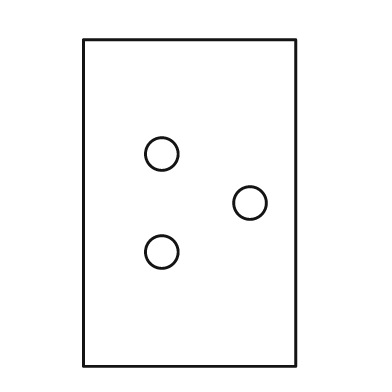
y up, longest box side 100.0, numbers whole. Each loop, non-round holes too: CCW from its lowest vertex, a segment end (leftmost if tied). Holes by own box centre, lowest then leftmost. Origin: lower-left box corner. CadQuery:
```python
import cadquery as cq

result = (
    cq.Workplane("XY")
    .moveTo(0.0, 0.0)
    .lineTo(65.0, 0.0)
    .lineTo(65.0, 100.0)
    .lineTo(0.0, 100.0)
    .close()
    .moveTo(24.0, 35.0)
    .circle(5.0)
    .moveTo(51.0, 50.0)
    .circle(5.0)
    .moveTo(24.0, 65.0)
    .circle(5.0)
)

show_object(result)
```